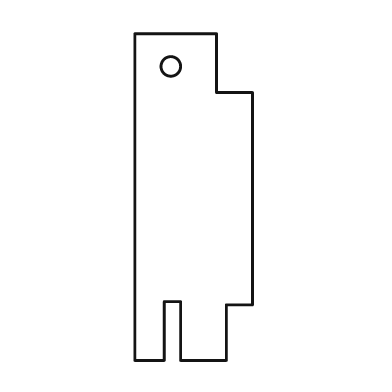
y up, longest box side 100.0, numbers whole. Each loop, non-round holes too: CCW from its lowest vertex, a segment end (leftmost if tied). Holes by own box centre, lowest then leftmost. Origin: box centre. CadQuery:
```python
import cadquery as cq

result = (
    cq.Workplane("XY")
    .moveTo(-18.0, -50.0)
    .lineTo(-9.0, -50.0)
    .lineTo(-9.0, -32.0)
    .lineTo(-4.0, -32.0)
    .lineTo(-4.0, -50.0)
    .lineTo(10.0, -50.0)
    .lineTo(10.0, -33.0)
    .lineTo(18.0, -33.0)
    .lineTo(18.0, 32.0)
    .lineTo(7.0, 32.0)
    .lineTo(7.0, 50.0)
    .lineTo(-18.0, 50.0)
    .close()
    .moveTo(-7.0, 40.0)
    .circle(3.0)
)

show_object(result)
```